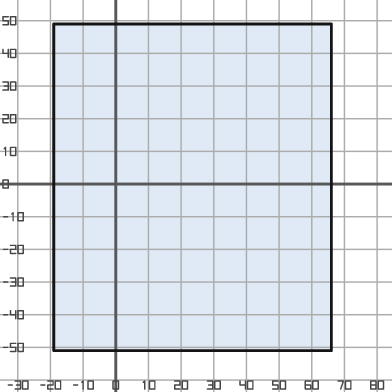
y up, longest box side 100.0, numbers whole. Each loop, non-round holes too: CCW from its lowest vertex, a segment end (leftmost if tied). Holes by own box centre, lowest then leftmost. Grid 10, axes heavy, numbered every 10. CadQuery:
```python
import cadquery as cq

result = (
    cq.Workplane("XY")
    .moveTo(-19.0, -51.0)
    .lineTo(66.0, -51.0)
    .lineTo(66.0, 49.0)
    .lineTo(-19.0, 49.0)
    .close()
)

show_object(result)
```